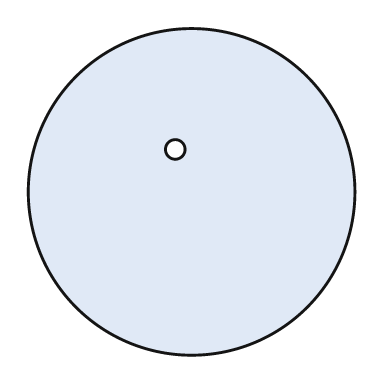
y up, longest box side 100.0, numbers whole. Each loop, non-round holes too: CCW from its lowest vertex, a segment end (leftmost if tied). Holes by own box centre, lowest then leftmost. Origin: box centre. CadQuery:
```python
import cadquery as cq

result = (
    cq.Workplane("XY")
    .moveTo(0.0, 0.0)
    .circle(50.0)
    .moveTo(-5.0, 13.0)
    .circle(3.0)
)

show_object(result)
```